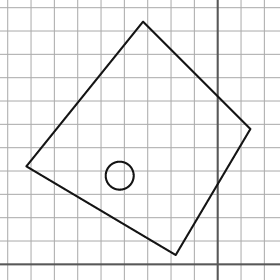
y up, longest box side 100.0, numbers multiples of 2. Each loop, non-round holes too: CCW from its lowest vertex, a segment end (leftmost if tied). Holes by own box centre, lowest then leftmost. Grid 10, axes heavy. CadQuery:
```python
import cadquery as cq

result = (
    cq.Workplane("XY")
    .moveTo(-18.0, 4.0)
    .lineTo(14.0, 58.0)
    .lineTo(-32.0, 104.0)
    .lineTo(-82.0, 42.0)
    .close()
    .moveTo(-42.0, 38.0)
    .circle(6.0)
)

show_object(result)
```